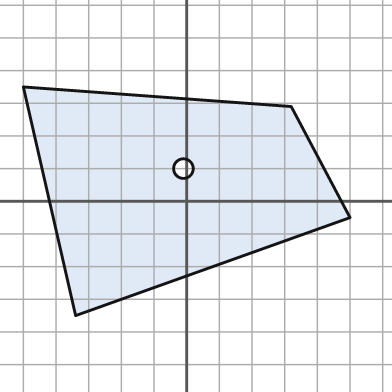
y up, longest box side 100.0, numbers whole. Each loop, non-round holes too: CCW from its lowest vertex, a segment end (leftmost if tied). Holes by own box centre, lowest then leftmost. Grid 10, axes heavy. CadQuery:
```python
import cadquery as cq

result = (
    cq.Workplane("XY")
    .moveTo(-34.0, -35.0)
    .lineTo(50.0, -5.0)
    .lineTo(32.0, 29.0)
    .lineTo(-50.0, 35.0)
    .close()
    .moveTo(-1.0, 10.0)
    .circle(3.0)
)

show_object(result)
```